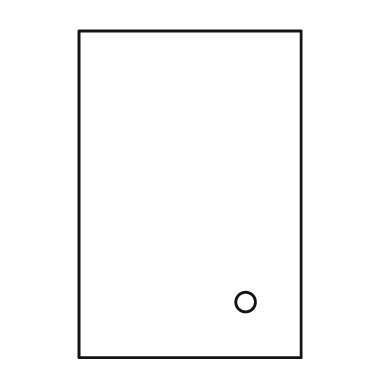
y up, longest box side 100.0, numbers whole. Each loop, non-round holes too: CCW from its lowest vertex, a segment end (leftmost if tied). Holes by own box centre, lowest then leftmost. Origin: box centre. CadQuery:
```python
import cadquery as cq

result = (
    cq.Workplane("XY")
    .moveTo(-34.0, -50.0)
    .lineTo(34.0, -50.0)
    .lineTo(34.0, 50.0)
    .lineTo(-34.0, 50.0)
    .close()
    .moveTo(17.0, -33.0)
    .circle(3.0)
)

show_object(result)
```